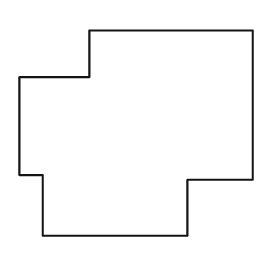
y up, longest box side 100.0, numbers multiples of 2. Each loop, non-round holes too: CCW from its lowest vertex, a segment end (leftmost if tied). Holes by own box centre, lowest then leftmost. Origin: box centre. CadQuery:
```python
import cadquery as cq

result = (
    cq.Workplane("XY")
    .moveTo(-40.0, -44.0)
    .lineTo(22.0, -44.0)
    .lineTo(22.0, -20.0)
    .lineTo(50.0, -20.0)
    .lineTo(50.0, 44.0)
    .lineTo(-20.0, 44.0)
    .lineTo(-20.0, 24.0)
    .lineTo(-50.0, 24.0)
    .lineTo(-50.0, -18.0)
    .lineTo(-40.0, -18.0)
    .close()
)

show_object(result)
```